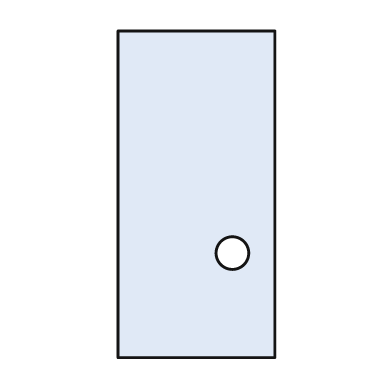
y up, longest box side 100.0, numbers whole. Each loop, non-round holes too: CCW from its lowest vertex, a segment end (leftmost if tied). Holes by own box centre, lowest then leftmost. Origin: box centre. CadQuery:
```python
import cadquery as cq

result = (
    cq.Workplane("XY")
    .moveTo(-24.0, -50.0)
    .lineTo(24.0, -50.0)
    .lineTo(24.0, 50.0)
    .lineTo(-24.0, 50.0)
    .close()
    .moveTo(11.0, -18.0)
    .circle(5.0)
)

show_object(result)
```